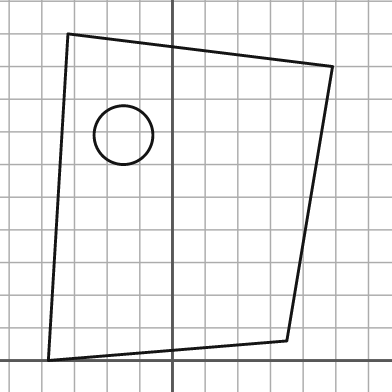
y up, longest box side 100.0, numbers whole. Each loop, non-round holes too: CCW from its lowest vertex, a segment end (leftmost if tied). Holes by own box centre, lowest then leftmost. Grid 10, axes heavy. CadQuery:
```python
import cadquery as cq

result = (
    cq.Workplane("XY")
    .moveTo(-38.0, 0.0)
    .lineTo(35.0, 6.0)
    .lineTo(49.0, 90.0)
    .lineTo(-32.0, 100.0)
    .close()
    .moveTo(-15.0, 69.0)
    .circle(9.0)
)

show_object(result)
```